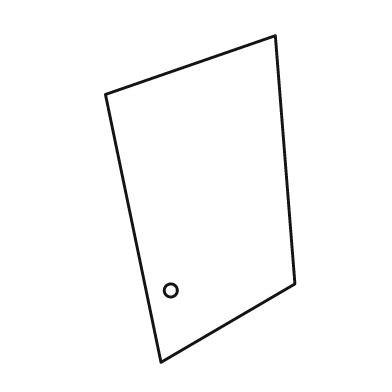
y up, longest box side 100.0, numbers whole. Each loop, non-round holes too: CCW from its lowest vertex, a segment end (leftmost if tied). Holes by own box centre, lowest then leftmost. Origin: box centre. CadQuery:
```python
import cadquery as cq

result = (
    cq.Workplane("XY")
    .moveTo(-12.0, -50.0)
    .lineTo(29.0, -26.0)
    .lineTo(23.0, 50.0)
    .lineTo(-29.0, 32.0)
    .close()
    .moveTo(-9.0, -28.0)
    .circle(2.0)
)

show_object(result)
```